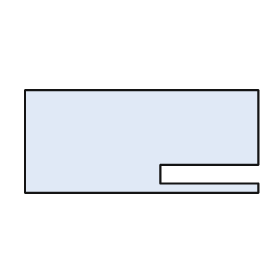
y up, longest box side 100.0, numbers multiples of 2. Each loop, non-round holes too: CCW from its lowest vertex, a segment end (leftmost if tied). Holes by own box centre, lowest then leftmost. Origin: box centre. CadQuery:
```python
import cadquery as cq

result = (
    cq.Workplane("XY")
    .moveTo(-50.0, -22.0)
    .lineTo(50.0, -22.0)
    .lineTo(50.0, -18.0)
    .lineTo(8.0, -18.0)
    .lineTo(8.0, -10.0)
    .lineTo(50.0, -10.0)
    .lineTo(50.0, 22.0)
    .lineTo(-50.0, 22.0)
    .close()
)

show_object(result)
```